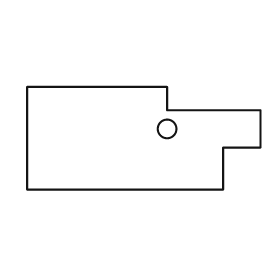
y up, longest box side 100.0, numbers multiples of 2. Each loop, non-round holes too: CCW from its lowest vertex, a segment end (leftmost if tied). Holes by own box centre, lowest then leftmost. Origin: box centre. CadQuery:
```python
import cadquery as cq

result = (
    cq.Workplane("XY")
    .moveTo(-50.0, -22.0)
    .lineTo(34.0, -22.0)
    .lineTo(34.0, -4.0)
    .lineTo(50.0, -4.0)
    .lineTo(50.0, 12.0)
    .lineTo(10.0, 12.0)
    .lineTo(10.0, 22.0)
    .lineTo(-50.0, 22.0)
    .close()
    .moveTo(10.0, 4.0)
    .circle(4.0)
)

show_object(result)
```